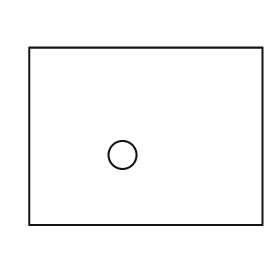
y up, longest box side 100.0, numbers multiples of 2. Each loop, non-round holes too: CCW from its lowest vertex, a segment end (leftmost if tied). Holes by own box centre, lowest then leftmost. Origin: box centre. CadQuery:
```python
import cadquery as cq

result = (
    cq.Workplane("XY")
    .moveTo(-50.0, -38.0)
    .lineTo(50.0, -38.0)
    .lineTo(50.0, 38.0)
    .lineTo(-50.0, 38.0)
    .close()
    .moveTo(-10.0, -8.0)
    .circle(6.0)
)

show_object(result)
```